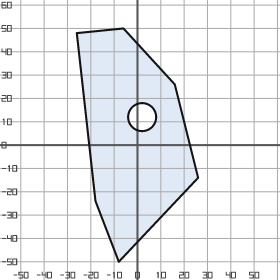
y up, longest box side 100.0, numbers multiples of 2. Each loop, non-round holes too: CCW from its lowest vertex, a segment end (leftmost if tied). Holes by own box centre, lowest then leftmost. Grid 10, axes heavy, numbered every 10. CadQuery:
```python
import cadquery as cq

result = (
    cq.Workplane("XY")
    .moveTo(-8.0, -50.0)
    .lineTo(26.0, -14.0)
    .lineTo(16.0, 26.0)
    .lineTo(-6.0, 50.0)
    .lineTo(-26.0, 48.0)
    .lineTo(-18.0, -24.0)
    .close()
    .moveTo(2.0, 12.0)
    .circle(6.0)
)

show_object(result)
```